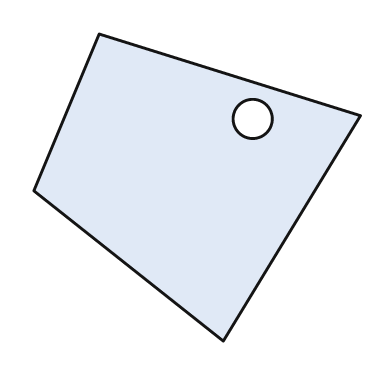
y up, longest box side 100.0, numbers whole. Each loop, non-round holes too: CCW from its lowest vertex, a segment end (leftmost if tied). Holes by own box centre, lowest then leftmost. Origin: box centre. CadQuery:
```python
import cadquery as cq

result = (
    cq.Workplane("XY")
    .moveTo(8.0, -47.0)
    .lineTo(50.0, 22.0)
    .lineTo(-30.0, 47.0)
    .lineTo(-50.0, -1.0)
    .close()
    .moveTo(17.0, 21.0)
    .circle(6.0)
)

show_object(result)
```